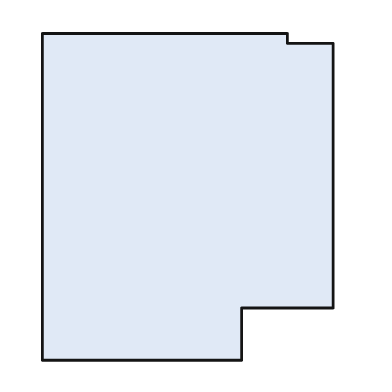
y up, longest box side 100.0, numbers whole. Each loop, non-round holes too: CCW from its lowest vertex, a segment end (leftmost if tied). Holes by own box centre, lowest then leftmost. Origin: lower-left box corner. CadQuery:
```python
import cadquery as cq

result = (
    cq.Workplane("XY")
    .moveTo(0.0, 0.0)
    .lineTo(61.0, 0.0)
    .lineTo(61.0, 16.0)
    .lineTo(89.0, 16.0)
    .lineTo(89.0, 97.0)
    .lineTo(75.0, 97.0)
    .lineTo(75.0, 100.0)
    .lineTo(0.0, 100.0)
    .close()
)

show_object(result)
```